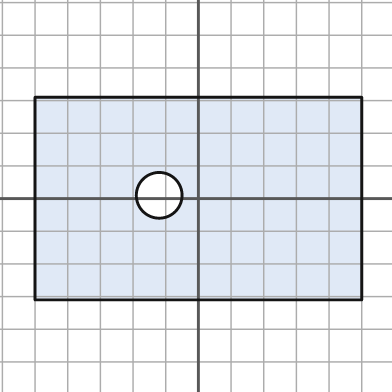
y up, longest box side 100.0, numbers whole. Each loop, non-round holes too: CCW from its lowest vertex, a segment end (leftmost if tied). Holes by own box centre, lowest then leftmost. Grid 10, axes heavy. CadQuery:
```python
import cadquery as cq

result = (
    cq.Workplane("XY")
    .moveTo(-50.0, -31.0)
    .lineTo(50.0, -31.0)
    .lineTo(50.0, 31.0)
    .lineTo(-50.0, 31.0)
    .close()
    .moveTo(-12.0, 1.0)
    .circle(7.0)
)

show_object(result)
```